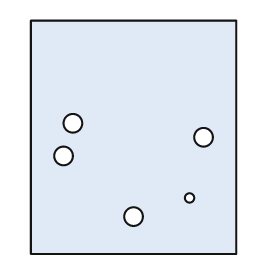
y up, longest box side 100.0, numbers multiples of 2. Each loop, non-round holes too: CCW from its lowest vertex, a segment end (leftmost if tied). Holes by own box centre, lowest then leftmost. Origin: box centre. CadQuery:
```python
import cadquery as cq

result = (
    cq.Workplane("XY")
    .moveTo(-44.0, -50.0)
    .lineTo(44.0, -50.0)
    .lineTo(44.0, 50.0)
    .lineTo(-44.0, 50.0)
    .close()
    .moveTo(0.0, -34.0)
    .circle(4.0)
    .moveTo(24.0, -26.0)
    .circle(2.0)
    .moveTo(-30.0, -8.0)
    .circle(4.0)
    .moveTo(30.0, 0.0)
    .circle(4.0)
    .moveTo(-26.0, 6.0)
    .circle(4.0)
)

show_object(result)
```